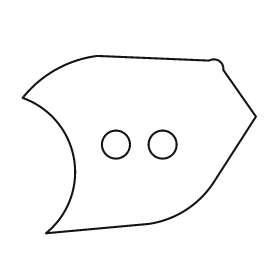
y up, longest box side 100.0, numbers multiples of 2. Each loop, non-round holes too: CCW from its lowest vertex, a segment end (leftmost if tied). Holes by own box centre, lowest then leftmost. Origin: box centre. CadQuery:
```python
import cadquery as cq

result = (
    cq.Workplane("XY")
    .moveTo(-40.0, -38.0)
    .lineTo(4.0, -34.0)
    .threePointArc((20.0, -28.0), (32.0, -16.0))
    .lineTo(50.0, 12.0)
    .lineTo(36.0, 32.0)
    .threePointArc((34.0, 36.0), (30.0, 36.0))
    .lineTo(-18.0, 38.0)
    .threePointArc((-36.0, 32.0), (-50.0, 20.0))
    .threePointArc((-28.0, -6.0), (-40.0, -38.0))
    .close()
    .moveTo(-10.0, 0.0)
    .circle(6.0)
    .moveTo(10.0, 0.0)
    .circle(6.0)
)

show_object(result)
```